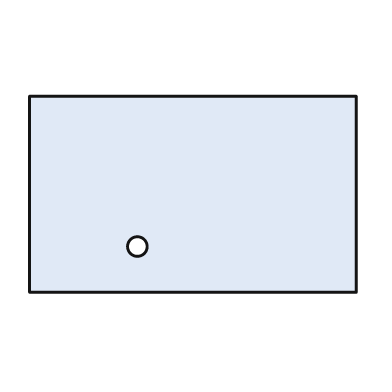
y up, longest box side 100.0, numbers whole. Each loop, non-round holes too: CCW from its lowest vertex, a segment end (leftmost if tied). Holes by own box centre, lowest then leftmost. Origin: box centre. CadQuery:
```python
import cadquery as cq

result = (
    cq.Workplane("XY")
    .moveTo(-50.0, -30.0)
    .lineTo(50.0, -30.0)
    .lineTo(50.0, 30.0)
    .lineTo(-50.0, 30.0)
    .close()
    .moveTo(-17.0, -16.0)
    .circle(3.0)
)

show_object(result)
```